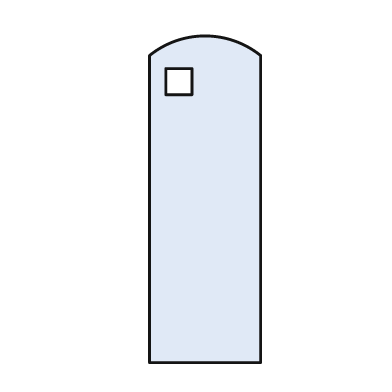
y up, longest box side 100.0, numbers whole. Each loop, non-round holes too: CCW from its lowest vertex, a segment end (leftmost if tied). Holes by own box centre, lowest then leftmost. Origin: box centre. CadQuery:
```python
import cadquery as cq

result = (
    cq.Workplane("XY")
    .moveTo(-17.0, -50.0)
    .lineTo(17.0, -50.0)
    .lineTo(17.0, 44.0)
    .threePointArc((0.0, 50.0), (-17.0, 44.0))
    .close()
    .moveTo(-12.0, 32.0)
    .lineTo(-4.0, 32.0)
    .lineTo(-4.0, 40.0)
    .lineTo(-12.0, 40.0)
    .close()
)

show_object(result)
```